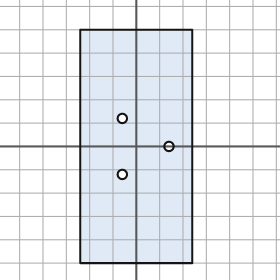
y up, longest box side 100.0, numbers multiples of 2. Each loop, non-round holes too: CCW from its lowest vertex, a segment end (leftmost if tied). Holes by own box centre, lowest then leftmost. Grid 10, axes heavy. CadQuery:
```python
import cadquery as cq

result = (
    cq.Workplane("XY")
    .moveTo(-24.0, -50.0)
    .lineTo(24.0, -50.0)
    .lineTo(24.0, 50.0)
    .lineTo(-24.0, 50.0)
    .close()
    .moveTo(-6.0, -12.0)
    .circle(2.0)
    .moveTo(14.0, 0.0)
    .circle(2.0)
    .moveTo(-6.0, 12.0)
    .circle(2.0)
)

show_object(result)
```